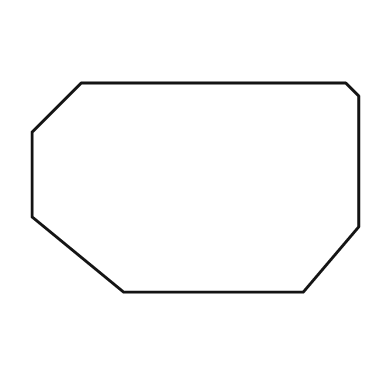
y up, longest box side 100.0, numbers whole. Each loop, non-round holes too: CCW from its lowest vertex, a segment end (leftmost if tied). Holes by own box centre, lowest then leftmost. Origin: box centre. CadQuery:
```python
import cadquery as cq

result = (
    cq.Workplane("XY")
    .moveTo(-22.0, -32.0)
    .lineTo(33.0, -32.0)
    .lineTo(50.0, -12.0)
    .lineTo(50.0, 28.0)
    .lineTo(46.0, 32.0)
    .lineTo(-35.0, 32.0)
    .lineTo(-50.0, 17.0)
    .lineTo(-50.0, -9.0)
    .close()
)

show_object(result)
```